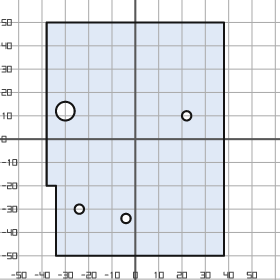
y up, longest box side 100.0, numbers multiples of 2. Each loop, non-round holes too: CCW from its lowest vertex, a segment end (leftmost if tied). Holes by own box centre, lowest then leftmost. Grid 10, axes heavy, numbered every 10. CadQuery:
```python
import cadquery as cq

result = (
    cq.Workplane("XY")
    .moveTo(-34.0, -50.0)
    .lineTo(38.0, -50.0)
    .lineTo(38.0, 50.0)
    .lineTo(-38.0, 50.0)
    .lineTo(-38.0, -20.0)
    .lineTo(-34.0, -20.0)
    .close()
    .moveTo(-4.0, -34.0)
    .circle(2.0)
    .moveTo(-24.0, -30.0)
    .circle(2.0)
    .moveTo(22.0, 10.0)
    .circle(2.0)
    .moveTo(-30.0, 12.0)
    .circle(4.0)
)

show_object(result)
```